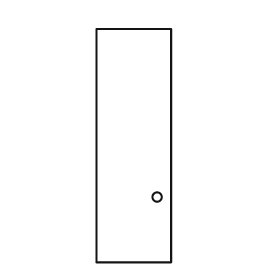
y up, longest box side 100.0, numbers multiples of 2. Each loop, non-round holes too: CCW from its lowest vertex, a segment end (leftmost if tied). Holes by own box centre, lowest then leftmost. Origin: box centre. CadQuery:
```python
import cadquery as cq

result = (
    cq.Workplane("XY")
    .moveTo(-16.0, -50.0)
    .lineTo(16.0, -50.0)
    .lineTo(16.0, 50.0)
    .lineTo(-16.0, 50.0)
    .close()
    .moveTo(10.0, -22.0)
    .circle(2.0)
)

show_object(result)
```